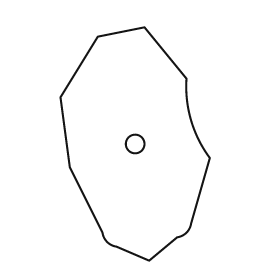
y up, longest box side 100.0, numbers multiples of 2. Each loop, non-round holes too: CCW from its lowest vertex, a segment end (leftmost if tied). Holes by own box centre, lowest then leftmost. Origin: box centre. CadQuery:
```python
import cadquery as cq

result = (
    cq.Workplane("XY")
    .moveTo(6.0, -50.0)
    .lineTo(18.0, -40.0)
    .threePointArc((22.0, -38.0), (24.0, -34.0))
    .lineTo(32.0, -6.0)
    .threePointArc((24.0, 10.0), (22.0, 28.0))
    .lineTo(4.0, 50.0)
    .lineTo(-16.0, 46.0)
    .lineTo(-32.0, 20.0)
    .lineTo(-28.0, -10.0)
    .lineTo(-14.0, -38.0)
    .threePointArc((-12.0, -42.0), (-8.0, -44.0))
    .close()
    .moveTo(0.0, 0.0)
    .circle(4.0)
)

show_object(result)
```